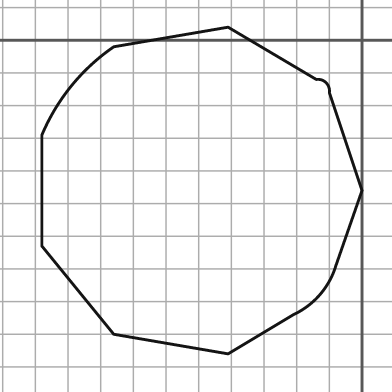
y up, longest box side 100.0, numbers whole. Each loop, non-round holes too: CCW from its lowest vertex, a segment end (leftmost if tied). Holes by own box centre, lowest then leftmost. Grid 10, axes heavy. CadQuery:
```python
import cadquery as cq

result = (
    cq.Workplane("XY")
    .moveTo(-41.0, -96.0)
    .lineTo(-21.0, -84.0)
    .threePointArc((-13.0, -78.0), (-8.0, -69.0))
    .lineTo(0.0, -46.0)
    .lineTo(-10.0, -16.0)
    .threePointArc((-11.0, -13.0), (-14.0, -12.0))
    .lineTo(-41.0, 4.0)
    .lineTo(-76.0, -2.0)
    .threePointArc((-89.0, -14.0), (-98.0, -29.0))
    .lineTo(-98.0, -63.0)
    .lineTo(-76.0, -90.0)
    .close()
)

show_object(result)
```